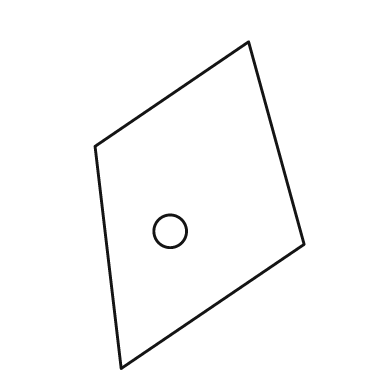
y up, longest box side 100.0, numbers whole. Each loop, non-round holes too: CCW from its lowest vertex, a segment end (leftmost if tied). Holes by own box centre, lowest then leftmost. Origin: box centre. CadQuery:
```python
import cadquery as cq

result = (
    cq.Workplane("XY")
    .moveTo(-24.0, -50.0)
    .lineTo(32.0, -12.0)
    .lineTo(15.0, 50.0)
    .lineTo(-32.0, 18.0)
    .close()
    .moveTo(-9.0, -8.0)
    .circle(5.0)
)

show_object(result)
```